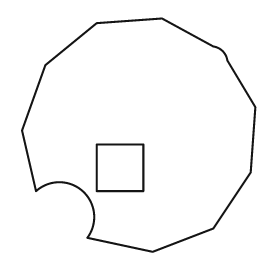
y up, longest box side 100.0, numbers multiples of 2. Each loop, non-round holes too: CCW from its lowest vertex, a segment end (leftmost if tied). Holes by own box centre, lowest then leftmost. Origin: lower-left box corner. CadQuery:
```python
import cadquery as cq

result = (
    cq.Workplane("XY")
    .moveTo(56.0, 0.0)
    .lineTo(82.0, 10.0)
    .lineTo(98.0, 34.0)
    .lineTo(100.0, 62.0)
    .lineTo(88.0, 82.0)
    .threePointArc((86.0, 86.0), (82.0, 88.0))
    .lineTo(60.0, 100.0)
    .lineTo(32.0, 98.0)
    .lineTo(10.0, 80.0)
    .lineTo(0.0, 52.0)
    .lineTo(6.0, 26.0)
    .threePointArc((26.0, 26.0), (28.0, 6.0))
    .close()
    .moveTo(32.0, 26.0)
    .lineTo(52.0, 26.0)
    .lineTo(52.0, 46.0)
    .lineTo(32.0, 46.0)
    .close()
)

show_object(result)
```